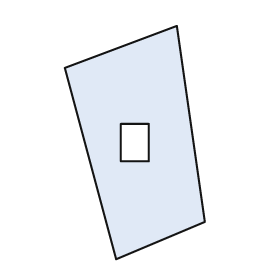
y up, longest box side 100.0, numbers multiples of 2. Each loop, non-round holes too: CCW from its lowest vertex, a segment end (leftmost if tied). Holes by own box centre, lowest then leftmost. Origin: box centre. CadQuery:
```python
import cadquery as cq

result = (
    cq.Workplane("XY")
    .moveTo(-8.0, -50.0)
    .lineTo(30.0, -34.0)
    .lineTo(18.0, 50.0)
    .lineTo(-30.0, 32.0)
    .close()
    .moveTo(-6.0, -8.0)
    .lineTo(6.0, -8.0)
    .lineTo(6.0, 8.0)
    .lineTo(-6.0, 8.0)
    .close()
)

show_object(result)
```